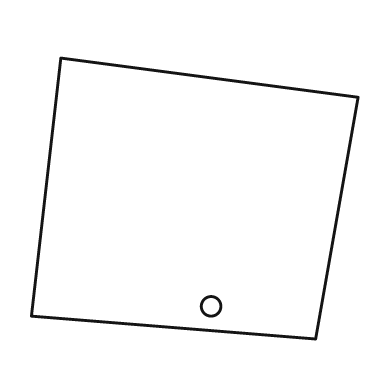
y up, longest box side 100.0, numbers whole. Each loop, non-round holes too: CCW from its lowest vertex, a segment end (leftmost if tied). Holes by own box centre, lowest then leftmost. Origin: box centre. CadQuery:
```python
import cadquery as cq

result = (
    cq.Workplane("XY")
    .moveTo(37.0, -43.0)
    .lineTo(50.0, 31.0)
    .lineTo(-41.0, 43.0)
    .lineTo(-50.0, -36.0)
    .close()
    .moveTo(5.0, -33.0)
    .circle(3.0)
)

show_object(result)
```